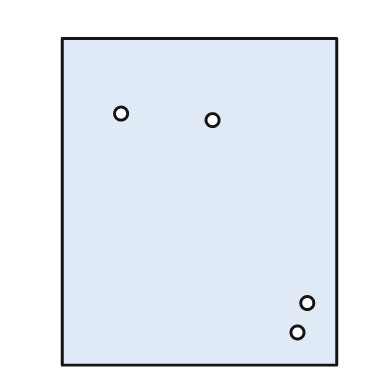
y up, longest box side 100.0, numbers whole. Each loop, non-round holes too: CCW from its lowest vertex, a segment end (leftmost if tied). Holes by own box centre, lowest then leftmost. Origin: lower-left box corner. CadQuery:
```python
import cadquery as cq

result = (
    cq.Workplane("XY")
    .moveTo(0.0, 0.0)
    .lineTo(84.0, 0.0)
    .lineTo(84.0, 100.0)
    .lineTo(0.0, 100.0)
    .close()
    .moveTo(72.0, 10.0)
    .circle(2.0)
    .moveTo(75.0, 19.0)
    .circle(2.0)
    .moveTo(46.0, 75.0)
    .circle(2.0)
    .moveTo(18.0, 77.0)
    .circle(2.0)
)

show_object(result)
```